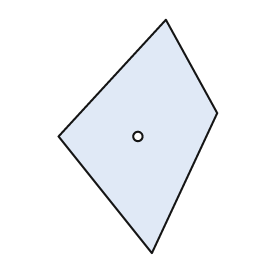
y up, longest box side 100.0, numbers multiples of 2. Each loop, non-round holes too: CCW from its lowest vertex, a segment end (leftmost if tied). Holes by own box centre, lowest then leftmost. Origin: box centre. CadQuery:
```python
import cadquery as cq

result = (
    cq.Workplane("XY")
    .moveTo(6.0, -50.0)
    .lineTo(34.0, 10.0)
    .lineTo(12.0, 50.0)
    .lineTo(-34.0, 0.0)
    .close()
    .moveTo(0.0, 0.0)
    .circle(2.0)
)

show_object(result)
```